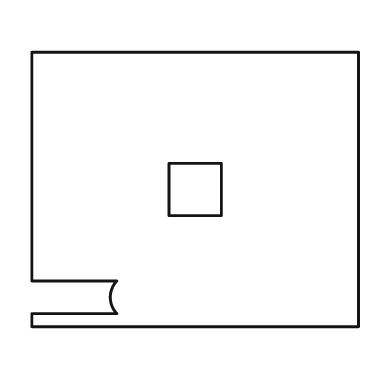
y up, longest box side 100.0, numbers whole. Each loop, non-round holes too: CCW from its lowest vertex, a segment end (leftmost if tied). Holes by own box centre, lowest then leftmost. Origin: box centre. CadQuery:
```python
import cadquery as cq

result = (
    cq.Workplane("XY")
    .moveTo(-50.0, -42.0)
    .lineTo(50.0, -42.0)
    .lineTo(50.0, 42.0)
    .lineTo(-50.0, 42.0)
    .lineTo(-50.0, -28.0)
    .lineTo(-24.0, -28.0)
    .threePointArc((-26.0, -33.0), (-24.0, -38.0))
    .lineTo(-50.0, -38.0)
    .close()
    .moveTo(-8.0, -8.0)
    .lineTo(8.0, -8.0)
    .lineTo(8.0, 8.0)
    .lineTo(-8.0, 8.0)
    .close()
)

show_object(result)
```